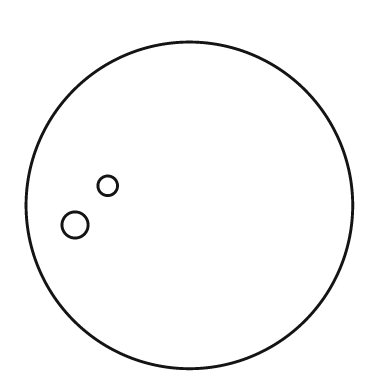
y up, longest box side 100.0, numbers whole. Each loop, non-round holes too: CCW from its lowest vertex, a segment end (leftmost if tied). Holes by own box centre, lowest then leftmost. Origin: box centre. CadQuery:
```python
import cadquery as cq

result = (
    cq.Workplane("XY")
    .moveTo(0.0, 0.0)
    .circle(50.0)
    .moveTo(-35.0, -6.0)
    .circle(4.0)
    .moveTo(-25.0, 6.0)
    .circle(3.0)
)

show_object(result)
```